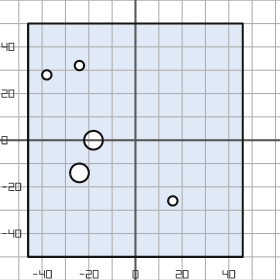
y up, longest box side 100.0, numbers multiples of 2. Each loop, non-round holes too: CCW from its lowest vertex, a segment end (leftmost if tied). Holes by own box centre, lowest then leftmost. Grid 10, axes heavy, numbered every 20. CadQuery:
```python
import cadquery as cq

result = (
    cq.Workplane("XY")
    .moveTo(-46.0, -50.0)
    .lineTo(46.0, -50.0)
    .lineTo(46.0, 50.0)
    .lineTo(-46.0, 50.0)
    .close()
    .moveTo(16.0, -26.0)
    .circle(2.0)
    .moveTo(-24.0, -14.0)
    .circle(4.0)
    .moveTo(-18.0, 0.0)
    .circle(4.0)
    .moveTo(-38.0, 28.0)
    .circle(2.0)
    .moveTo(-24.0, 32.0)
    .circle(2.0)
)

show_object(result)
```